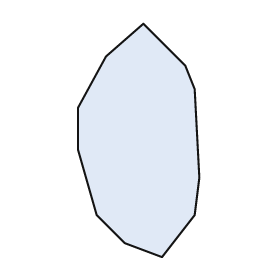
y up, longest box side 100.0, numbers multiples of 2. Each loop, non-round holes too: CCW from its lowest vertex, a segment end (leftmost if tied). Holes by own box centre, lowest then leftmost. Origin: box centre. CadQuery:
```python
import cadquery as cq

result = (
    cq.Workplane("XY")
    .moveTo(10.0, -50.0)
    .lineTo(24.0, -32.0)
    .lineTo(26.0, -16.0)
    .lineTo(24.0, 22.0)
    .lineTo(20.0, 32.0)
    .lineTo(2.0, 50.0)
    .lineTo(-14.0, 36.0)
    .lineTo(-26.0, 14.0)
    .lineTo(-26.0, -4.0)
    .lineTo(-18.0, -32.0)
    .lineTo(-6.0, -44.0)
    .close()
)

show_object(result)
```